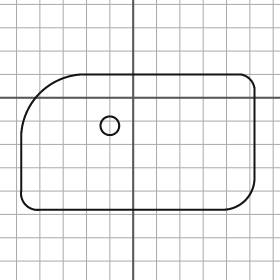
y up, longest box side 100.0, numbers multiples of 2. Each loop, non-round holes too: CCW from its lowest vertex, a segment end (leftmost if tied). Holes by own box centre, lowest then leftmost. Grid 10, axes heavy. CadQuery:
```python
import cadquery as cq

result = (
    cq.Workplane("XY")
    .moveTo(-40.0, -48.0)
    .lineTo(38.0, -48.0)
    .threePointArc((48.0, -44.0), (52.0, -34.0))
    .lineTo(52.0, 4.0)
    .threePointArc((50.0, 8.0), (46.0, 10.0))
    .lineTo(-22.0, 10.0)
    .threePointArc((-40.0, 2.0), (-48.0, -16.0))
    .lineTo(-48.0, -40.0)
    .threePointArc((-46.0, -46.0), (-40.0, -48.0))
    .close()
    .moveTo(-10.0, -12.0)
    .circle(4.0)
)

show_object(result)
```